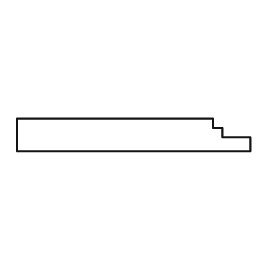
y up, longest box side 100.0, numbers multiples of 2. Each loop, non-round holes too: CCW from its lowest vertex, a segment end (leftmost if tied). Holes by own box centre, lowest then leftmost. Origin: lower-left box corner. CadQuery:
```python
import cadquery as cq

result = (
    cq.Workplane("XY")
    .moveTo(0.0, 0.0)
    .lineTo(100.0, 0.0)
    .lineTo(100.0, 6.0)
    .lineTo(88.0, 6.0)
    .lineTo(88.0, 10.0)
    .lineTo(84.0, 10.0)
    .lineTo(84.0, 14.0)
    .lineTo(0.0, 14.0)
    .close()
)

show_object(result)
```